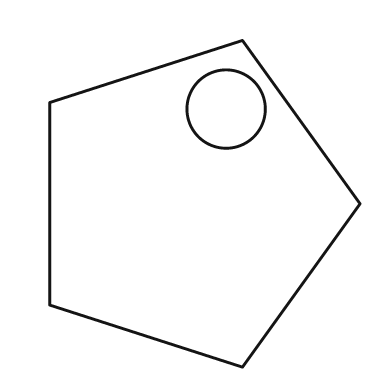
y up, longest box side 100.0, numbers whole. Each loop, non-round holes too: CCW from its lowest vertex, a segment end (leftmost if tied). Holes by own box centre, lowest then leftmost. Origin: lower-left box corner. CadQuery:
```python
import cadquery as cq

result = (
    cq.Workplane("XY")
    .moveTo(59.0, 0.0)
    .lineTo(95.0, 50.0)
    .lineTo(59.0, 100.0)
    .lineTo(0.0, 81.0)
    .lineTo(0.0, 19.0)
    .close()
    .moveTo(54.0, 79.0)
    .circle(12.0)
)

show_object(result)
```